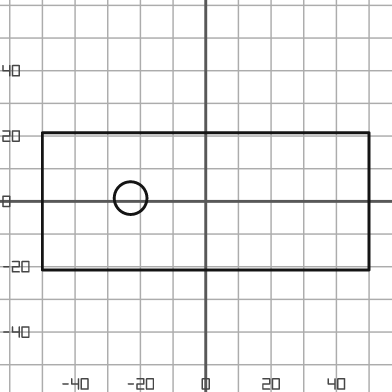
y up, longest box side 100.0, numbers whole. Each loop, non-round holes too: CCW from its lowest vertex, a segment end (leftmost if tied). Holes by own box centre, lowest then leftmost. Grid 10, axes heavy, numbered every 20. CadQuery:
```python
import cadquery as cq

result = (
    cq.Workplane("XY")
    .moveTo(-50.0, -21.0)
    .lineTo(50.0, -21.0)
    .lineTo(50.0, 21.0)
    .lineTo(-50.0, 21.0)
    .close()
    .moveTo(-23.0, 1.0)
    .circle(5.0)
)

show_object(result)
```